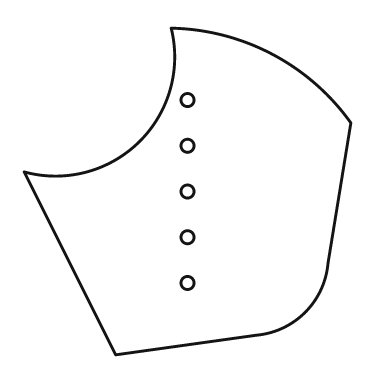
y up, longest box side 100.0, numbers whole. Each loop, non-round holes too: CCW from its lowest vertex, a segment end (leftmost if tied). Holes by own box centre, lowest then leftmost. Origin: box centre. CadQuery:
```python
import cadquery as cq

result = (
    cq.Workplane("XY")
    .moveTo(-22.0, -50.0)
    .lineTo(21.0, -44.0)
    .threePointArc((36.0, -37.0), (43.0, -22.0))
    .lineTo(50.0, 21.0)
    .threePointArc((26.0, 42.0), (-5.0, 50.0))
    .threePointArc((-15.0, 15.0), (-50.0, 6.0))
    .close()
    .moveTo(0.0, -28.0)
    .circle(2.0)
    .moveTo(0.0, -14.0)
    .circle(2.0)
    .moveTo(0.0, 0.0)
    .circle(2.0)
    .moveTo(0.0, 14.0)
    .circle(2.0)
    .moveTo(0.0, 28.0)
    .circle(2.0)
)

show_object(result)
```